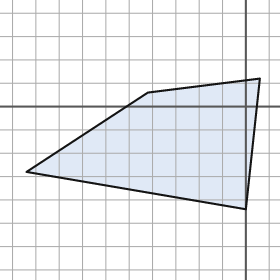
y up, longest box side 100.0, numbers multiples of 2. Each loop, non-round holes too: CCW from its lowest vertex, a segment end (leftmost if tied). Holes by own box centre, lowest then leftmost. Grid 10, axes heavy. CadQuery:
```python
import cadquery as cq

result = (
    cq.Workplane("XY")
    .moveTo(0.0, -44.0)
    .lineTo(6.0, 12.0)
    .lineTo(-42.0, 6.0)
    .lineTo(-94.0, -28.0)
    .close()
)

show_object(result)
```